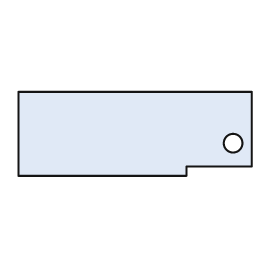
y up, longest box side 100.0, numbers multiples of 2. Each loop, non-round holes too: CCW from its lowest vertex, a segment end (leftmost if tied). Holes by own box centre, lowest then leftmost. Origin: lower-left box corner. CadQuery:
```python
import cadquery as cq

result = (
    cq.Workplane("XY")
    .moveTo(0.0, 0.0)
    .lineTo(72.0, 0.0)
    .lineTo(72.0, 4.0)
    .lineTo(100.0, 4.0)
    .lineTo(100.0, 36.0)
    .lineTo(0.0, 36.0)
    .close()
    .moveTo(92.0, 14.0)
    .circle(4.0)
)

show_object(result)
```